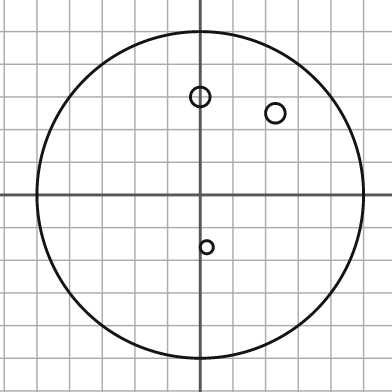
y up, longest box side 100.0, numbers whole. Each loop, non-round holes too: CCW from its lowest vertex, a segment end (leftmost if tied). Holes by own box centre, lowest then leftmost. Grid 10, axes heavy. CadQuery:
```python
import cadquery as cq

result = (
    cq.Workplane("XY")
    .moveTo(0.0, 0.0)
    .circle(50.0)
    .moveTo(2.0, -16.0)
    .circle(2.0)
    .moveTo(23.0, 25.0)
    .circle(3.0)
    .moveTo(0.0, 30.0)
    .circle(3.0)
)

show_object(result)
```